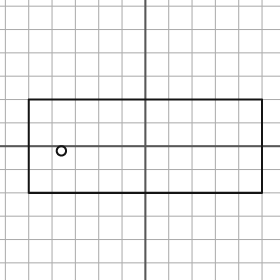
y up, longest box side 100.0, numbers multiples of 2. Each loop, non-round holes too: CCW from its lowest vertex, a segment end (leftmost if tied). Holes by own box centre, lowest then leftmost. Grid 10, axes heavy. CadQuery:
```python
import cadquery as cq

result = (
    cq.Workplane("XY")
    .moveTo(-50.0, -20.0)
    .lineTo(50.0, -20.0)
    .lineTo(50.0, 20.0)
    .lineTo(-50.0, 20.0)
    .close()
    .moveTo(-36.0, -2.0)
    .circle(2.0)
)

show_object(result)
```